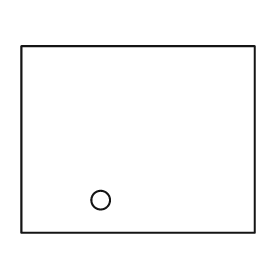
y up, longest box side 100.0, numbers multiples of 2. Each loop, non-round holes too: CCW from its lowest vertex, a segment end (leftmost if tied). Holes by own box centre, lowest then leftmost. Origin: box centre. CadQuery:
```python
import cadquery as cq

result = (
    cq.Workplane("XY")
    .moveTo(-50.0, -40.0)
    .lineTo(50.0, -40.0)
    .lineTo(50.0, 40.0)
    .lineTo(-50.0, 40.0)
    .close()
    .moveTo(-16.0, -26.0)
    .circle(4.0)
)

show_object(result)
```